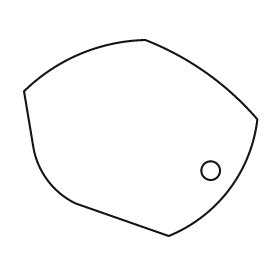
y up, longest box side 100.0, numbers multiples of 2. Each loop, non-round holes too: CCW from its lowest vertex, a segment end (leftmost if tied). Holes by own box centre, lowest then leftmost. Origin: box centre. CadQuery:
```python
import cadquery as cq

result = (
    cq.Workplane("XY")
    .moveTo(12.0, -42.0)
    .threePointArc((38.0, -22.0), (50.0, 8.0))
    .threePointArc((28.0, 28.0), (2.0, 42.0))
    .threePointArc((-26.0, 36.0), (-50.0, 20.0))
    .lineTo(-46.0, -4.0)
    .threePointArc((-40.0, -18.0), (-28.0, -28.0))
    .close()
    .moveTo(30.0, -14.0)
    .circle(4.0)
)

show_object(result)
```